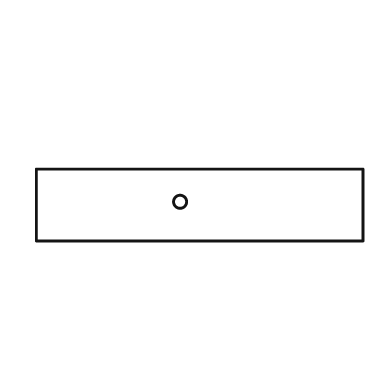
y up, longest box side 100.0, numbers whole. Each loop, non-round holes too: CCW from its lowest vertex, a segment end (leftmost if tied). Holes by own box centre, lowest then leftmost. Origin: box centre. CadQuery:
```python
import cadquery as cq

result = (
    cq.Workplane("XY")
    .moveTo(-50.0, -11.0)
    .lineTo(50.0, -11.0)
    .lineTo(50.0, 11.0)
    .lineTo(-50.0, 11.0)
    .close()
    .moveTo(-6.0, 1.0)
    .circle(2.0)
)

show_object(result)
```